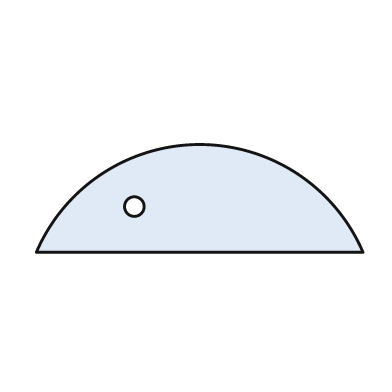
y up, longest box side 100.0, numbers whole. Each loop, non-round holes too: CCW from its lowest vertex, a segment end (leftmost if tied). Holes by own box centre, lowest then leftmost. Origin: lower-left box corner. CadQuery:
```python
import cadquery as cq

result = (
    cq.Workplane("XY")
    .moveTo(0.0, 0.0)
    .lineTo(100.0, 0.0)
    .threePointArc((50.0, 33.0), (0.0, 0.0))
    .close()
    .moveTo(30.0, 14.0)
    .circle(3.0)
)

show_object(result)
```